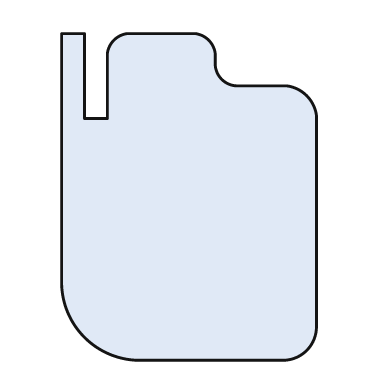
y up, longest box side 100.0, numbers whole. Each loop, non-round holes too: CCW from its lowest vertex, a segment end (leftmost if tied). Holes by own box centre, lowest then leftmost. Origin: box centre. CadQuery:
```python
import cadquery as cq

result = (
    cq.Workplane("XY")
    .moveTo(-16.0, -50.0)
    .lineTo(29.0, -50.0)
    .threePointArc((36.0, -47.0), (39.0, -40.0))
    .lineTo(39.0, 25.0)
    .threePointArc((36.0, 31.0), (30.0, 34.0))
    .lineTo(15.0, 34.0)
    .threePointArc((10.0, 36.0), (8.0, 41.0))
    .lineTo(8.0, 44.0)
    .threePointArc((6.0, 48.0), (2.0, 50.0))
    .lineTo(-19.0, 50.0)
    .threePointArc((-23.0, 48.0), (-25.0, 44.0))
    .lineTo(-25.0, 24.0)
    .lineTo(-32.0, 24.0)
    .lineTo(-32.0, 50.0)
    .lineTo(-39.0, 50.0)
    .lineTo(-39.0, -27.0)
    .threePointArc((-32.0, -43.0), (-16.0, -50.0))
    .close()
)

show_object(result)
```